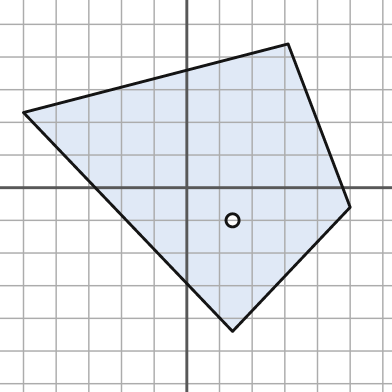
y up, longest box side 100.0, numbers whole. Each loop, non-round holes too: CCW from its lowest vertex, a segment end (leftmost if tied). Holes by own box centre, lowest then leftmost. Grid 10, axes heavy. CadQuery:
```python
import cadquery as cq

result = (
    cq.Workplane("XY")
    .moveTo(14.0, -44.0)
    .lineTo(50.0, -6.0)
    .lineTo(31.0, 44.0)
    .lineTo(-50.0, 23.0)
    .close()
    .moveTo(14.0, -10.0)
    .circle(2.0)
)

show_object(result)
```